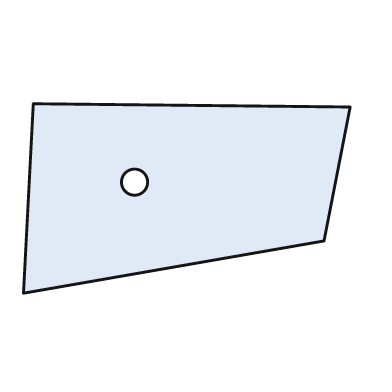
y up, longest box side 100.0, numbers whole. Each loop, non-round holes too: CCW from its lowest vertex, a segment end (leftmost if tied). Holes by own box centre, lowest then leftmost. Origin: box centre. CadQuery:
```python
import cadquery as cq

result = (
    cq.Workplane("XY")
    .moveTo(-50.0, -29.0)
    .lineTo(42.0, -13.0)
    .lineTo(50.0, 28.0)
    .lineTo(-47.0, 29.0)
    .close()
    .moveTo(-16.0, 5.0)
    .circle(4.0)
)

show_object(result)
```